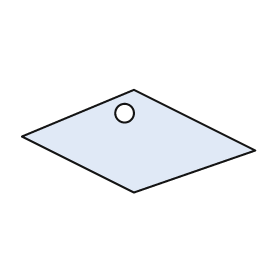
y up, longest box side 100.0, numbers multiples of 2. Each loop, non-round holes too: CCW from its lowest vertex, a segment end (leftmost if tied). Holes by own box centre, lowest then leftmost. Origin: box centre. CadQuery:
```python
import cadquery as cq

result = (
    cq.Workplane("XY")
    .moveTo(-2.0, -22.0)
    .lineTo(50.0, -4.0)
    .lineTo(-2.0, 22.0)
    .lineTo(-50.0, 2.0)
    .close()
    .moveTo(-6.0, 12.0)
    .circle(4.0)
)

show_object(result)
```